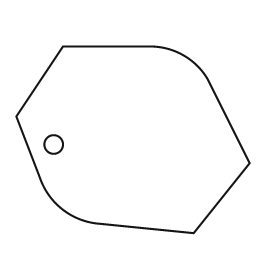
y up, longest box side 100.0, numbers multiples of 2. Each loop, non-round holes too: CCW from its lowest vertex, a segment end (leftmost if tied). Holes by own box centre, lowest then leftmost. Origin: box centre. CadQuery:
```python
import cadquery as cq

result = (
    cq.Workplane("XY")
    .moveTo(26.0, -40.0)
    .lineTo(50.0, -10.0)
    .lineTo(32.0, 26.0)
    .threePointArc((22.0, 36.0), (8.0, 40.0))
    .lineTo(-30.0, 40.0)
    .lineTo(-50.0, 10.0)
    .lineTo(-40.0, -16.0)
    .threePointArc((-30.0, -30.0), (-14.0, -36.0))
    .close()
    .moveTo(-34.0, -2.0)
    .circle(4.0)
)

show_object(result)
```